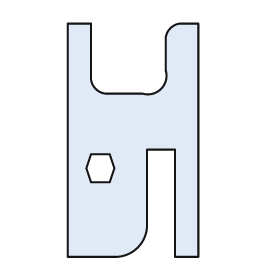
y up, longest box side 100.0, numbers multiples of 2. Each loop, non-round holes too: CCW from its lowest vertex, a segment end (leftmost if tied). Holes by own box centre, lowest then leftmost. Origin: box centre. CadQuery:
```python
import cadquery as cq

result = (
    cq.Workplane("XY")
    .moveTo(-28.0, -50.0)
    .lineTo(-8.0, -50.0)
    .threePointArc((2.0, -46.0), (6.0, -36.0))
    .lineTo(6.0, -4.0)
    .lineTo(18.0, -4.0)
    .lineTo(18.0, -50.0)
    .lineTo(28.0, -50.0)
    .lineTo(28.0, 50.0)
    .lineTo(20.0, 50.0)
    .threePointArc((16.0, 48.0), (14.0, 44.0))
    .lineTo(14.0, 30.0)
    .threePointArc((12.0, 22.0), (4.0, 20.0))
    .lineTo(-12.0, 20.0)
    .threePointArc((-16.0, 22.0), (-18.0, 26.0))
    .lineTo(-18.0, 50.0)
    .lineTo(-28.0, 50.0)
    .close()
    .moveTo(-18.0, -18.0)
    .lineTo(-10.0, -18.0)
    .lineTo(-8.0, -12.0)
    .lineTo(-10.0, -6.0)
    .lineTo(-18.0, -6.0)
    .lineTo(-20.0, -12.0)
    .close()
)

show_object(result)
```